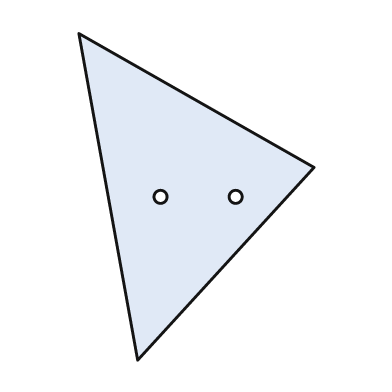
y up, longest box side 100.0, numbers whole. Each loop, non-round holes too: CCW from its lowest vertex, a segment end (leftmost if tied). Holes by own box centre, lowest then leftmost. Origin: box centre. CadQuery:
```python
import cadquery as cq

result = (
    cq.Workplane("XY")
    .moveTo(-18.0, -50.0)
    .lineTo(36.0, 9.0)
    .lineTo(-36.0, 50.0)
    .close()
    .moveTo(-11.0, 0.0)
    .circle(2.0)
    .moveTo(12.0, 0.0)
    .circle(2.0)
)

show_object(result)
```